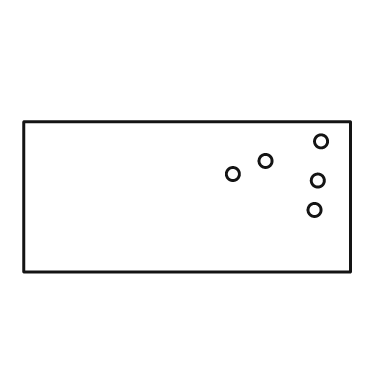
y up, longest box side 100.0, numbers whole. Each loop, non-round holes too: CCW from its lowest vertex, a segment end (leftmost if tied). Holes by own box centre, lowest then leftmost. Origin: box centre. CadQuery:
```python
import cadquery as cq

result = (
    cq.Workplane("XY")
    .moveTo(-50.0, -23.0)
    .lineTo(50.0, -23.0)
    .lineTo(50.0, 23.0)
    .lineTo(-50.0, 23.0)
    .close()
    .moveTo(39.0, -4.0)
    .circle(2.0)
    .moveTo(40.0, 5.0)
    .circle(2.0)
    .moveTo(14.0, 7.0)
    .circle(2.0)
    .moveTo(24.0, 11.0)
    .circle(2.0)
    .moveTo(41.0, 17.0)
    .circle(2.0)
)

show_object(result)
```